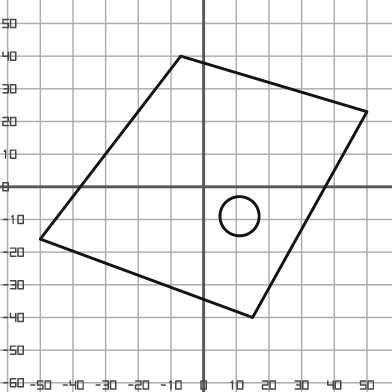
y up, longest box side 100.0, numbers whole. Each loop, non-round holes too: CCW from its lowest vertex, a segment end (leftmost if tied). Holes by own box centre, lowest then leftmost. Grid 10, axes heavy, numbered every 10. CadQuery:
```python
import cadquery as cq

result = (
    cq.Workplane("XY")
    .moveTo(15.0, -40.0)
    .lineTo(50.0, 23.0)
    .lineTo(-7.0, 40.0)
    .lineTo(-50.0, -16.0)
    .close()
    .moveTo(11.0, -9.0)
    .circle(6.0)
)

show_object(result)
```